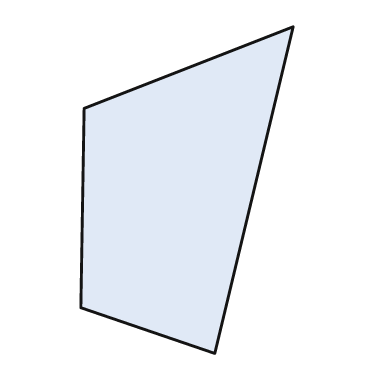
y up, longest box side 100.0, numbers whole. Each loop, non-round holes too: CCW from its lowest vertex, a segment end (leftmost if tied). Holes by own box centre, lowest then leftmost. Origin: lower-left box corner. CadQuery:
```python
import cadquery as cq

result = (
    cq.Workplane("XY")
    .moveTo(41.0, 0.0)
    .lineTo(65.0, 100.0)
    .lineTo(1.0, 75.0)
    .lineTo(0.0, 14.0)
    .close()
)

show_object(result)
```